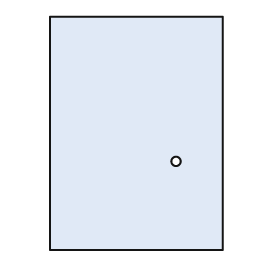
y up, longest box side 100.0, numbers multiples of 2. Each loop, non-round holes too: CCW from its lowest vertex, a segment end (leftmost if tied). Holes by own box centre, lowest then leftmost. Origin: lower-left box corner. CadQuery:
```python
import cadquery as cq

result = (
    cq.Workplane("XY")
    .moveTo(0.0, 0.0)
    .lineTo(74.0, 0.0)
    .lineTo(74.0, 100.0)
    .lineTo(0.0, 100.0)
    .close()
    .moveTo(54.0, 38.0)
    .circle(2.0)
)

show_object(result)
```